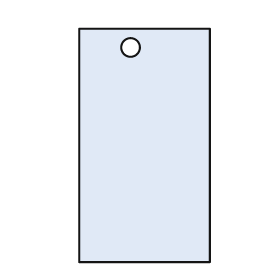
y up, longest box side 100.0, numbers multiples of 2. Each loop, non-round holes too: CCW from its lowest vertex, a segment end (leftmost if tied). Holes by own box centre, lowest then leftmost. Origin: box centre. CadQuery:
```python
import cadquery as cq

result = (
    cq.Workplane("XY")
    .moveTo(-28.0, -50.0)
    .lineTo(28.0, -50.0)
    .lineTo(28.0, 50.0)
    .lineTo(-28.0, 50.0)
    .close()
    .moveTo(-6.0, 42.0)
    .circle(4.0)
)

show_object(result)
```